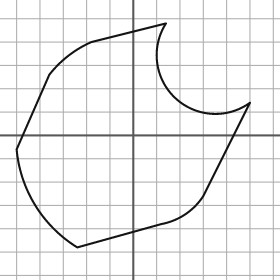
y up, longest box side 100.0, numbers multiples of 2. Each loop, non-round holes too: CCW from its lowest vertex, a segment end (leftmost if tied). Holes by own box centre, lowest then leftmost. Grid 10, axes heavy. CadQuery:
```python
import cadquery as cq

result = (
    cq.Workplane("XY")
    .moveTo(-24.0, -48.0)
    .lineTo(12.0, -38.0)
    .threePointArc((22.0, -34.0), (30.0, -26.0))
    .lineTo(50.0, 14.0)
    .threePointArc((18.0, 16.0), (14.0, 48.0))
    .lineTo(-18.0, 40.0)
    .threePointArc((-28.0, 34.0), (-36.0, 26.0))
    .lineTo(-50.0, -6.0)
    .threePointArc((-42.0, -30.0), (-24.0, -48.0))
    .close()
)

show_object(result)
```